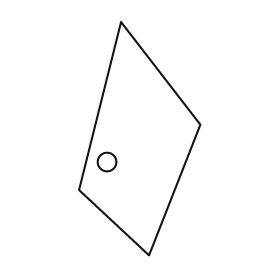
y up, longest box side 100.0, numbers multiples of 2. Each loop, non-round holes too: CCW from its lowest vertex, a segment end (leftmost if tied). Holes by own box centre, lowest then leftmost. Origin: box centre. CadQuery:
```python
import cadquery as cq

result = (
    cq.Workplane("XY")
    .moveTo(4.0, -50.0)
    .lineTo(26.0, 6.0)
    .lineTo(-8.0, 50.0)
    .lineTo(-26.0, -22.0)
    .close()
    .moveTo(-14.0, -10.0)
    .circle(4.0)
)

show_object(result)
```